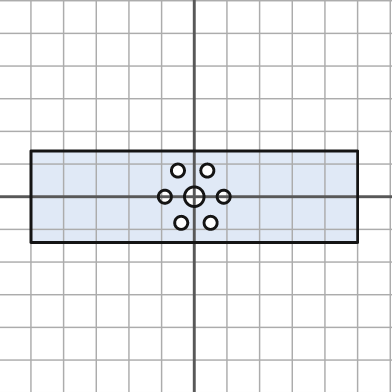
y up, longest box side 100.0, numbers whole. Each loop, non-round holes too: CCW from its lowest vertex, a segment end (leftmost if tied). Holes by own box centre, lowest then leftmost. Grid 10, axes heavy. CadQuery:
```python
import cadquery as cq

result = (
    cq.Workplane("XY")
    .moveTo(-50.0, -14.0)
    .lineTo(50.0, -14.0)
    .lineTo(50.0, 14.0)
    .lineTo(-50.0, 14.0)
    .close()
    .moveTo(-4.0, -8.0)
    .circle(2.0)
    .moveTo(5.0, -8.0)
    .circle(2.0)
    .moveTo(-9.0, 0.0)
    .circle(2.0)
    .moveTo(0.0, 0.0)
    .circle(3.0)
    .moveTo(9.0, 0.0)
    .circle(2.0)
    .moveTo(-5.0, 8.0)
    .circle(2.0)
    .moveTo(4.0, 8.0)
    .circle(2.0)
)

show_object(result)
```